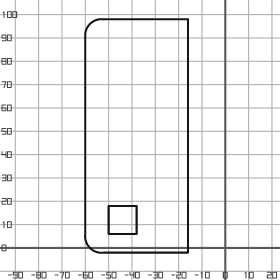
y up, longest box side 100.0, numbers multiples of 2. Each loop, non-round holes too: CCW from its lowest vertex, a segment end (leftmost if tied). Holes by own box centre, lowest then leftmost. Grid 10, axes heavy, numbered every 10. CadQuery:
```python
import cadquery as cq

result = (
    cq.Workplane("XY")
    .moveTo(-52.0, -2.0)
    .lineTo(-16.0, -2.0)
    .lineTo(-16.0, 98.0)
    .lineTo(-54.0, 98.0)
    .threePointArc((-58.0, 96.0), (-60.0, 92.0))
    .lineTo(-60.0, 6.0)
    .threePointArc((-58.0, 0.0), (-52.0, -2.0))
    .close()
    .moveTo(-50.0, 6.0)
    .lineTo(-38.0, 6.0)
    .lineTo(-38.0, 18.0)
    .lineTo(-50.0, 18.0)
    .close()
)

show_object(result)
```